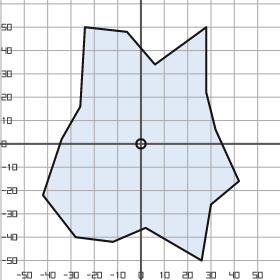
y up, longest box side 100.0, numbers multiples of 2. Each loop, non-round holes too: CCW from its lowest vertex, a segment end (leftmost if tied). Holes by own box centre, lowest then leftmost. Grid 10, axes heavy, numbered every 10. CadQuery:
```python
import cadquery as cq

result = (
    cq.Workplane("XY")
    .moveTo(26.0, -50.0)
    .lineTo(30.0, -26.0)
    .lineTo(42.0, -16.0)
    .lineTo(32.0, 6.0)
    .lineTo(28.0, 22.0)
    .lineTo(28.0, 50.0)
    .lineTo(6.0, 34.0)
    .lineTo(-6.0, 48.0)
    .lineTo(-24.0, 50.0)
    .lineTo(-26.0, 16.0)
    .lineTo(-34.0, 2.0)
    .lineTo(-42.0, -22.0)
    .lineTo(-28.0, -40.0)
    .lineTo(-12.0, -42.0)
    .lineTo(2.0, -36.0)
    .close()
    .moveTo(0.0, 0.0)
    .circle(2.0)
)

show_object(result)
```